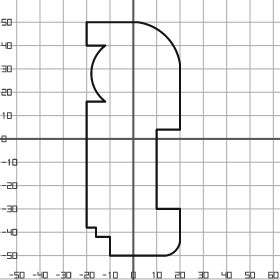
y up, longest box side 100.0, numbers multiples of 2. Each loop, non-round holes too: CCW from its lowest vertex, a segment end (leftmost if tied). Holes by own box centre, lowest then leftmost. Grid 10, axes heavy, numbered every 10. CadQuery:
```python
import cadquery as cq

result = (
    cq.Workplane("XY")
    .moveTo(-10.0, -50.0)
    .lineTo(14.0, -50.0)
    .threePointArc((18.0, -48.0), (20.0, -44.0))
    .lineTo(20.0, -30.0)
    .lineTo(10.0, -30.0)
    .lineTo(10.0, 4.0)
    .lineTo(20.0, 4.0)
    .lineTo(20.0, 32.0)
    .threePointArc((14.0, 44.0), (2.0, 50.0))
    .lineTo(-20.0, 50.0)
    .lineTo(-20.0, 40.0)
    .lineTo(-12.0, 40.0)
    .threePointArc((-18.0, 28.0), (-12.0, 16.0))
    .lineTo(-20.0, 16.0)
    .lineTo(-20.0, -38.0)
    .lineTo(-16.0, -38.0)
    .lineTo(-16.0, -42.0)
    .lineTo(-10.0, -42.0)
    .close()
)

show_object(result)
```